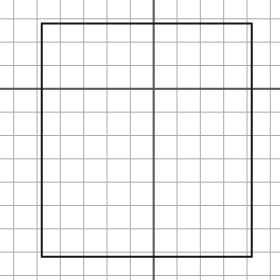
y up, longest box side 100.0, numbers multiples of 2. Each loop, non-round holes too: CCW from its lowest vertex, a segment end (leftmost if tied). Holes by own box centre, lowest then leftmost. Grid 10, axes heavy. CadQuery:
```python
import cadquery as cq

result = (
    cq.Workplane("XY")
    .moveTo(-48.0, -72.0)
    .lineTo(42.0, -72.0)
    .lineTo(42.0, 28.0)
    .lineTo(-48.0, 28.0)
    .close()
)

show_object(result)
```